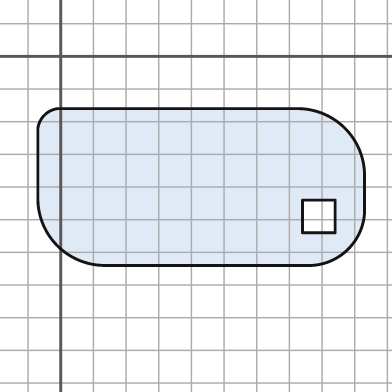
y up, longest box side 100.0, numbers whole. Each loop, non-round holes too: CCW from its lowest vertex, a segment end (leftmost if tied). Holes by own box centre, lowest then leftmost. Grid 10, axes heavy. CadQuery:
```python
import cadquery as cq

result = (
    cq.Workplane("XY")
    .moveTo(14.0, -64.0)
    .lineTo(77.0, -64.0)
    .threePointArc((88.0, -59.0), (93.0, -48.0))
    .lineTo(93.0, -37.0)
    .threePointArc((87.0, -22.0), (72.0, -16.0))
    .lineTo(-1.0, -16.0)
    .threePointArc((-5.0, -18.0), (-7.0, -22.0))
    .lineTo(-7.0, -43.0)
    .threePointArc((-1.0, -58.0), (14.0, -64.0))
    .close()
    .moveTo(74.0, -54.0)
    .lineTo(84.0, -54.0)
    .lineTo(84.0, -44.0)
    .lineTo(74.0, -44.0)
    .close()
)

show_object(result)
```